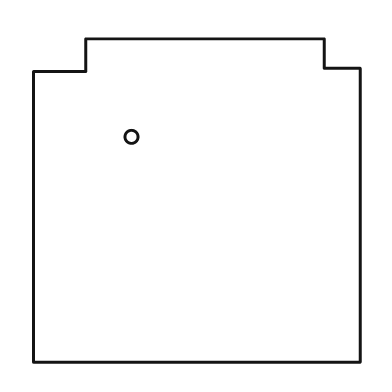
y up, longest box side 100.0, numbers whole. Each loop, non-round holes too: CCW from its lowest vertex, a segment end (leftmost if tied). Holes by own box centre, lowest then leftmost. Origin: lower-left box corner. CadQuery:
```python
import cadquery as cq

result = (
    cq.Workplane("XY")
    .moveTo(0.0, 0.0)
    .lineTo(100.0, 0.0)
    .lineTo(100.0, 90.0)
    .lineTo(89.0, 90.0)
    .lineTo(89.0, 99.0)
    .lineTo(16.0, 99.0)
    .lineTo(16.0, 89.0)
    .lineTo(0.0, 89.0)
    .close()
    .moveTo(30.0, 69.0)
    .circle(2.0)
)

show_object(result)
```